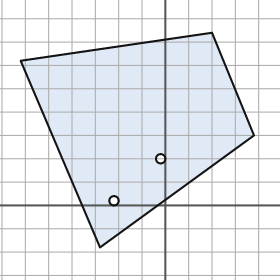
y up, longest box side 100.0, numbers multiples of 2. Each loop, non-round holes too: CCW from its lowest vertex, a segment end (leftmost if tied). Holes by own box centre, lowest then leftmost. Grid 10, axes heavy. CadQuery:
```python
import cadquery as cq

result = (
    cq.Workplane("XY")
    .moveTo(-28.0, -18.0)
    .lineTo(38.0, 30.0)
    .lineTo(20.0, 74.0)
    .lineTo(-62.0, 62.0)
    .close()
    .moveTo(-22.0, 2.0)
    .circle(2.0)
    .moveTo(-2.0, 20.0)
    .circle(2.0)
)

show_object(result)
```